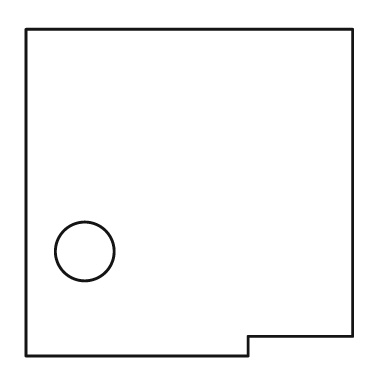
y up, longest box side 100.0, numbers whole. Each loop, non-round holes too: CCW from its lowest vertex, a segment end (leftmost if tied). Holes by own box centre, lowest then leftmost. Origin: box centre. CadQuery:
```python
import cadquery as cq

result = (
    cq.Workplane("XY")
    .moveTo(-50.0, -50.0)
    .lineTo(18.0, -50.0)
    .lineTo(18.0, -44.0)
    .lineTo(50.0, -44.0)
    .lineTo(50.0, 50.0)
    .lineTo(-50.0, 50.0)
    .close()
    .moveTo(-32.0, -18.0)
    .circle(9.0)
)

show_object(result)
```